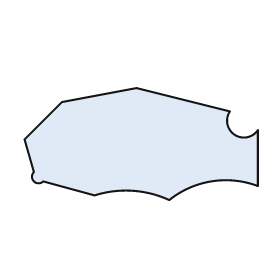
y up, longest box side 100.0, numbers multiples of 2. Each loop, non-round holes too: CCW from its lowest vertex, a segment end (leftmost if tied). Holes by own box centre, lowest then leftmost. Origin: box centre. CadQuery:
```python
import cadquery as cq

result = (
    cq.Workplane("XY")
    .moveTo(12.0, -24.0)
    .threePointArc((30.0, -16.0), (50.0, -18.0))
    .lineTo(50.0, 6.0)
    .threePointArc((40.0, 4.0), (38.0, 14.0))
    .lineTo(-2.0, 24.0)
    .lineTo(-34.0, 18.0)
    .lineTo(-50.0, 2.0)
    .lineTo(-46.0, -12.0)
    .threePointArc((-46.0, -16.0), (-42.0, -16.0))
    .lineTo(-20.0, -22.0)
    .threePointArc((-4.0, -20.0), (12.0, -24.0))
    .close()
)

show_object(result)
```